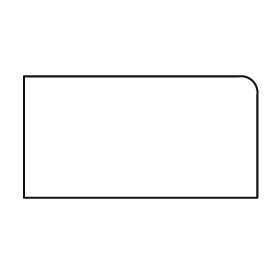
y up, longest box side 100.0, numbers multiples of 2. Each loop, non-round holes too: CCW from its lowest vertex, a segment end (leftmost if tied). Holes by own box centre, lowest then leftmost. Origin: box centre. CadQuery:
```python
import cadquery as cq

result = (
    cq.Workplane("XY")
    .moveTo(-50.0, -26.0)
    .lineTo(50.0, -26.0)
    .lineTo(50.0, 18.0)
    .threePointArc((48.0, 24.0), (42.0, 26.0))
    .lineTo(-50.0, 26.0)
    .close()
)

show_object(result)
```